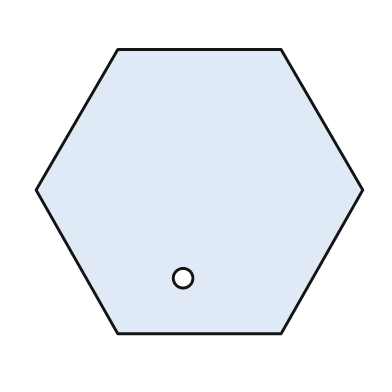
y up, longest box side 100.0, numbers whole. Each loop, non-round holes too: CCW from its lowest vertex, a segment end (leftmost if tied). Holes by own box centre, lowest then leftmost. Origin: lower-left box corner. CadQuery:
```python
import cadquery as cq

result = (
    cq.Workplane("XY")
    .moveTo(25.0, 0.0)
    .lineTo(75.0, 0.0)
    .lineTo(100.0, 44.0)
    .lineTo(75.0, 87.0)
    .lineTo(25.0, 87.0)
    .lineTo(0.0, 44.0)
    .close()
    .moveTo(45.0, 17.0)
    .circle(3.0)
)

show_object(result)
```